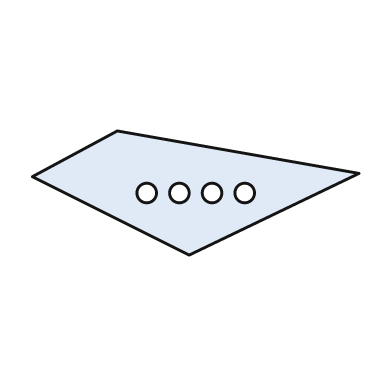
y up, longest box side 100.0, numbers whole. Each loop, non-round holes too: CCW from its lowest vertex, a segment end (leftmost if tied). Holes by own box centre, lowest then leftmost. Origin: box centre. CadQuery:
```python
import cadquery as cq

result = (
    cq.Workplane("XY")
    .moveTo(-2.0, -19.0)
    .lineTo(50.0, 6.0)
    .lineTo(-24.0, 19.0)
    .lineTo(-50.0, 5.0)
    .close()
    .moveTo(-15.0, 0.0)
    .circle(3.0)
    .moveTo(-5.0, 0.0)
    .circle(3.0)
    .moveTo(5.0, 0.0)
    .circle(3.0)
    .moveTo(15.0, 0.0)
    .circle(3.0)
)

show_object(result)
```